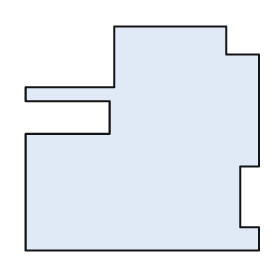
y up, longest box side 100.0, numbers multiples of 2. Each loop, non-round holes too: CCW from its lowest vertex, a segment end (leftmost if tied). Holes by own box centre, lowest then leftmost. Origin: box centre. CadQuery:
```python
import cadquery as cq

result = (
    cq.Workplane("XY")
    .moveTo(-50.0, -48.0)
    .lineTo(50.0, -48.0)
    .lineTo(50.0, -38.0)
    .lineTo(42.0, -38.0)
    .lineTo(42.0, -12.0)
    .lineTo(50.0, -12.0)
    .lineTo(50.0, 36.0)
    .lineTo(36.0, 36.0)
    .lineTo(36.0, 48.0)
    .lineTo(-12.0, 48.0)
    .lineTo(-12.0, 22.0)
    .lineTo(-50.0, 22.0)
    .lineTo(-50.0, 16.0)
    .lineTo(-14.0, 16.0)
    .lineTo(-14.0, 2.0)
    .lineTo(-50.0, 2.0)
    .close()
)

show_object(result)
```